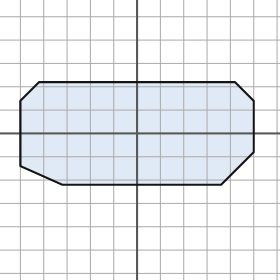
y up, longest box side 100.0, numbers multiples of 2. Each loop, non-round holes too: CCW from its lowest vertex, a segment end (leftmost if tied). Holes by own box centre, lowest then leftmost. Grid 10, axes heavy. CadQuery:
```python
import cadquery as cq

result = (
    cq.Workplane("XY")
    .moveTo(-32.0, -22.0)
    .lineTo(36.0, -22.0)
    .lineTo(50.0, -8.0)
    .lineTo(50.0, 14.0)
    .lineTo(42.0, 22.0)
    .lineTo(-42.0, 22.0)
    .lineTo(-50.0, 14.0)
    .lineTo(-50.0, -14.0)
    .close()
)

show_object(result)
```